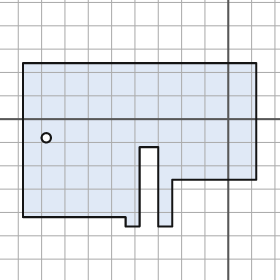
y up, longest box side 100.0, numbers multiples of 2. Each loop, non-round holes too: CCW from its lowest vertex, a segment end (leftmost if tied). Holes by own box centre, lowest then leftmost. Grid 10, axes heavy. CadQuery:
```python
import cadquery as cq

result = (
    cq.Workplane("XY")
    .moveTo(-44.0, -46.0)
    .lineTo(-38.0, -46.0)
    .lineTo(-38.0, -12.0)
    .lineTo(-30.0, -12.0)
    .lineTo(-30.0, -46.0)
    .lineTo(-24.0, -46.0)
    .lineTo(-24.0, -26.0)
    .lineTo(12.0, -26.0)
    .lineTo(12.0, 24.0)
    .lineTo(-88.0, 24.0)
    .lineTo(-88.0, -42.0)
    .lineTo(-44.0, -42.0)
    .close()
    .moveTo(-78.0, -8.0)
    .circle(2.0)
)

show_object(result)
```